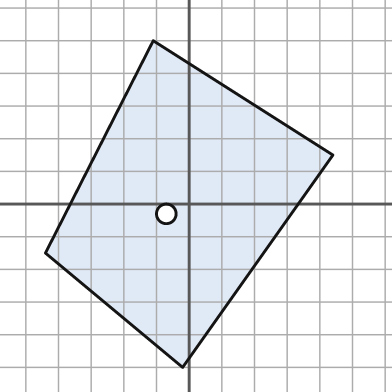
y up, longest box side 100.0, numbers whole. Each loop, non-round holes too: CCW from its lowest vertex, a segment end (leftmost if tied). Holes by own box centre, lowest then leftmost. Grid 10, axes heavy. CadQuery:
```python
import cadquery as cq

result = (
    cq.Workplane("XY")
    .moveTo(-2.0, -50.0)
    .lineTo(44.0, 15.0)
    .lineTo(-11.0, 50.0)
    .lineTo(-44.0, -15.0)
    .close()
    .moveTo(-7.0, -3.0)
    .circle(3.0)
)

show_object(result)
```